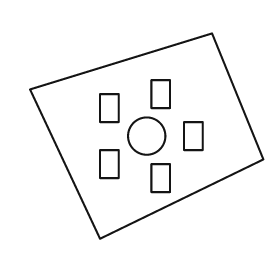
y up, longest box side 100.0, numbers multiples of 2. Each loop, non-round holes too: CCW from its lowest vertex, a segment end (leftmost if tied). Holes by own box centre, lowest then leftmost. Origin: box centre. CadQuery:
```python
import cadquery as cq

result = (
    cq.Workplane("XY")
    .moveTo(-20.0, -44.0)
    .lineTo(50.0, -10.0)
    .lineTo(28.0, 44.0)
    .lineTo(-50.0, 20.0)
    .close()
    .moveTo(2.0, -24.0)
    .lineTo(10.0, -24.0)
    .lineTo(10.0, -12.0)
    .lineTo(2.0, -12.0)
    .close()
    .moveTo(-20.0, -18.0)
    .lineTo(-12.0, -18.0)
    .lineTo(-12.0, -6.0)
    .lineTo(-20.0, -6.0)
    .close()
    .moveTo(0.0, 0.0)
    .circle(8.0)
    .moveTo(16.0, -6.0)
    .lineTo(24.0, -6.0)
    .lineTo(24.0, 6.0)
    .lineTo(16.0, 6.0)
    .close()
    .moveTo(-20.0, 6.0)
    .lineTo(-12.0, 6.0)
    .lineTo(-12.0, 18.0)
    .lineTo(-20.0, 18.0)
    .close()
    .moveTo(2.0, 12.0)
    .lineTo(10.0, 12.0)
    .lineTo(10.0, 24.0)
    .lineTo(2.0, 24.0)
    .close()
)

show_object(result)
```